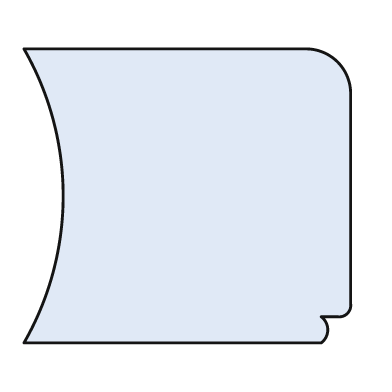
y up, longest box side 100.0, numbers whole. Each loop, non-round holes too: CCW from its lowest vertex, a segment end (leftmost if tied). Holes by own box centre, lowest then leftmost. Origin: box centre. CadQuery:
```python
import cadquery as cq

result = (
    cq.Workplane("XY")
    .moveTo(-50.0, -45.0)
    .lineTo(41.0, -45.0)
    .threePointArc((43.0, -41.0), (41.0, -37.0))
    .lineTo(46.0, -37.0)
    .threePointArc((49.0, -36.0), (50.0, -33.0))
    .lineTo(50.0, 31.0)
    .threePointArc((46.0, 41.0), (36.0, 45.0))
    .lineTo(-50.0, 45.0)
    .threePointArc((-38.0, 0.0), (-50.0, -45.0))
    .close()
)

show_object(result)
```